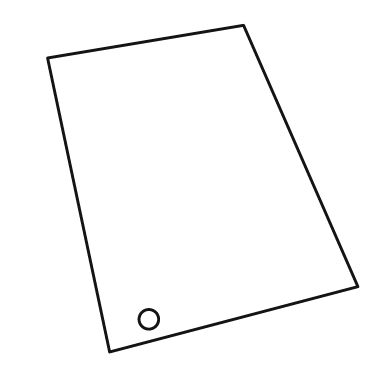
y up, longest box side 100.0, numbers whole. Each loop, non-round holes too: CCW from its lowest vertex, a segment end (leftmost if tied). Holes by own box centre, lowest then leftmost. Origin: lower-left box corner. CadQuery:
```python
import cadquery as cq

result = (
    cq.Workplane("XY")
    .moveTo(19.0, 0.0)
    .lineTo(95.0, 20.0)
    .lineTo(60.0, 100.0)
    .lineTo(0.0, 90.0)
    .close()
    .moveTo(31.0, 10.0)
    .circle(3.0)
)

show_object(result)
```